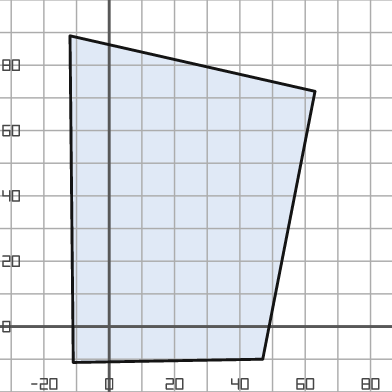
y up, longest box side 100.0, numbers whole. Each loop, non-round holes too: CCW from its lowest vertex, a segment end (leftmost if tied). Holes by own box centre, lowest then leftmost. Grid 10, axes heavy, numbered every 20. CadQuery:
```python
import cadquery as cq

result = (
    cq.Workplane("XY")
    .moveTo(-11.0, -11.0)
    .lineTo(47.0, -10.0)
    .lineTo(63.0, 72.0)
    .lineTo(-12.0, 89.0)
    .close()
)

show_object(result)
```